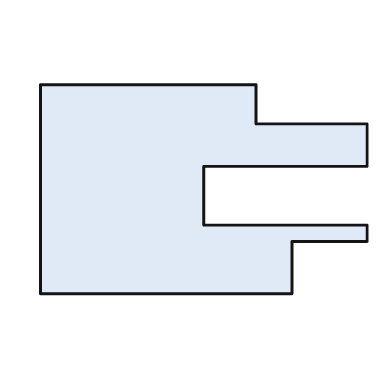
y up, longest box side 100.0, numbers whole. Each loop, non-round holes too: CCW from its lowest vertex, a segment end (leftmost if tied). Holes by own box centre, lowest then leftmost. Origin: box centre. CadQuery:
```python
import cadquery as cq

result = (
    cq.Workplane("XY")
    .moveTo(-50.0, -32.0)
    .lineTo(27.0, -32.0)
    .lineTo(27.0, -16.0)
    .lineTo(50.0, -16.0)
    .lineTo(50.0, -11.0)
    .lineTo(0.0, -11.0)
    .lineTo(0.0, 7.0)
    .lineTo(50.0, 7.0)
    .lineTo(50.0, 20.0)
    .lineTo(16.0, 20.0)
    .lineTo(16.0, 32.0)
    .lineTo(-50.0, 32.0)
    .close()
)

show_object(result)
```